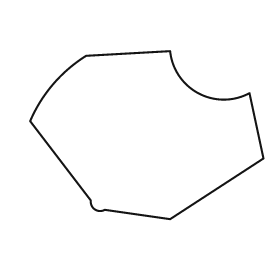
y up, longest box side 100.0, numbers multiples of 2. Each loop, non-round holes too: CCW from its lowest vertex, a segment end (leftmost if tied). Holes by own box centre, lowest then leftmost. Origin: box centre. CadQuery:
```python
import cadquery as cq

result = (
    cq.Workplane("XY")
    .moveTo(10.0, -36.0)
    .lineTo(50.0, -10.0)
    .lineTo(44.0, 18.0)
    .threePointArc((22.0, 18.0), (10.0, 36.0))
    .lineTo(-26.0, 34.0)
    .threePointArc((-40.0, 22.0), (-50.0, 6.0))
    .lineTo(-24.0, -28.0)
    .threePointArc((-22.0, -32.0), (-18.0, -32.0))
    .close()
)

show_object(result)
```